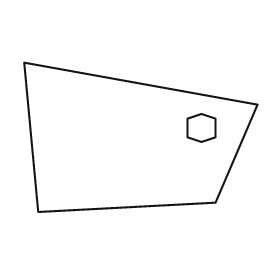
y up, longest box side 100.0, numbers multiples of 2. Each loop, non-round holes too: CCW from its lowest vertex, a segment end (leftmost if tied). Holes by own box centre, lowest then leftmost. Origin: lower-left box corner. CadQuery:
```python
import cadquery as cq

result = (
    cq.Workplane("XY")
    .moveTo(6.0, 0.0)
    .lineTo(82.0, 4.0)
    .lineTo(100.0, 46.0)
    .lineTo(0.0, 64.0)
    .close()
    .moveTo(76.0, 30.0)
    .lineTo(82.0, 32.0)
    .lineTo(82.0, 40.0)
    .lineTo(76.0, 42.0)
    .lineTo(70.0, 40.0)
    .lineTo(70.0, 32.0)
    .close()
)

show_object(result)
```